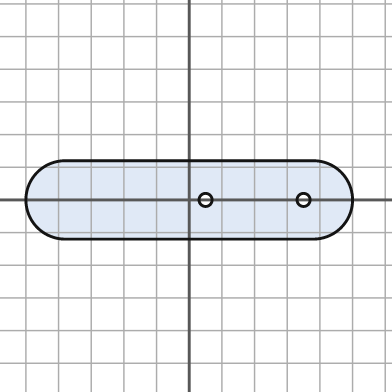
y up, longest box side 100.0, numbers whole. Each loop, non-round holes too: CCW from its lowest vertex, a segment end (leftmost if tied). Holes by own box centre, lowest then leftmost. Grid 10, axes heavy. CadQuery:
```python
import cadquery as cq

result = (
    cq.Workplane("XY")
    .moveTo(-38.0, -12.0)
    .lineTo(38.0, -12.0)
    .threePointArc((50.0, 0.0), (38.0, 12.0))
    .lineTo(-38.0, 12.0)
    .threePointArc((-50.0, 0.0), (-38.0, -12.0))
    .close()
    .moveTo(5.0, 0.0)
    .circle(2.0)
    .moveTo(35.0, 0.0)
    .circle(2.0)
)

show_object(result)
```